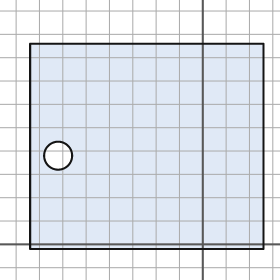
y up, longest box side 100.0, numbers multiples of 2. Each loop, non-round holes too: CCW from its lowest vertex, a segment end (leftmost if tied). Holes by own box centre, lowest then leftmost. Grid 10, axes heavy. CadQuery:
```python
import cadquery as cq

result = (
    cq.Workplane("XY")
    .moveTo(-74.0, -2.0)
    .lineTo(26.0, -2.0)
    .lineTo(26.0, 86.0)
    .lineTo(-74.0, 86.0)
    .close()
    .moveTo(-62.0, 38.0)
    .circle(6.0)
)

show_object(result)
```